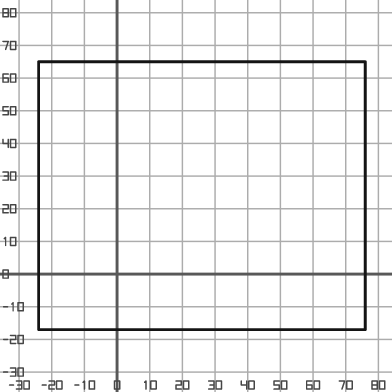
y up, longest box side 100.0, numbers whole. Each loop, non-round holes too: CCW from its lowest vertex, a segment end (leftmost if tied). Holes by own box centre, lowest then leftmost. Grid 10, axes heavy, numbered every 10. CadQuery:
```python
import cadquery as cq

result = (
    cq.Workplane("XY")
    .moveTo(-24.0, -17.0)
    .lineTo(76.0, -17.0)
    .lineTo(76.0, 65.0)
    .lineTo(-24.0, 65.0)
    .close()
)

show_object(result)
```